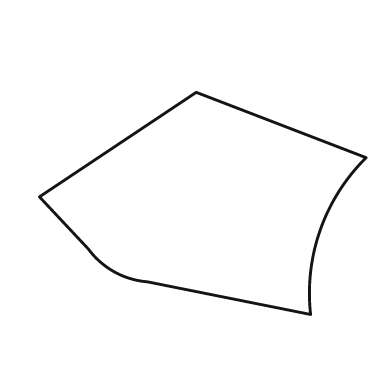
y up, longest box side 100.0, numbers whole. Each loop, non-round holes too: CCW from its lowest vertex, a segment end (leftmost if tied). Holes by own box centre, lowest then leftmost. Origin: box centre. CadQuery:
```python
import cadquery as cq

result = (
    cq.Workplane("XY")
    .moveTo(33.0, -34.0)
    .threePointArc((36.0, -8.0), (50.0, 14.0))
    .lineTo(-2.0, 34.0)
    .lineTo(-50.0, 2.0)
    .lineTo(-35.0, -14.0)
    .threePointArc((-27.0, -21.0), (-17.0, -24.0))
    .close()
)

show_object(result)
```